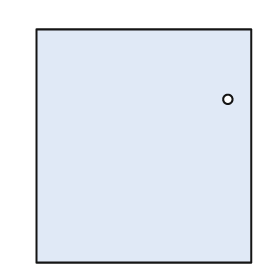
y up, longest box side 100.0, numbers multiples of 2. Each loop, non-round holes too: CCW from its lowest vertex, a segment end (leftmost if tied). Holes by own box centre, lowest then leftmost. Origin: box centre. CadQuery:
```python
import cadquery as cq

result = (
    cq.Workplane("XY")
    .moveTo(-46.0, -50.0)
    .lineTo(46.0, -50.0)
    .lineTo(46.0, 50.0)
    .lineTo(-46.0, 50.0)
    .close()
    .moveTo(36.0, 20.0)
    .circle(2.0)
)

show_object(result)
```